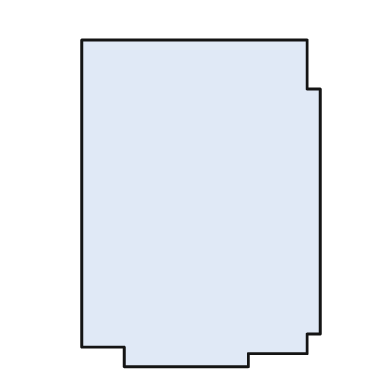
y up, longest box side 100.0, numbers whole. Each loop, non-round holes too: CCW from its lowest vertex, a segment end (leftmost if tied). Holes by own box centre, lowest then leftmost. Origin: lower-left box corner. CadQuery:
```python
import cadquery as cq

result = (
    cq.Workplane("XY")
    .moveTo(13.0, 0.0)
    .lineTo(51.0, 0.0)
    .lineTo(51.0, 4.0)
    .lineTo(69.0, 4.0)
    .lineTo(69.0, 10.0)
    .lineTo(73.0, 10.0)
    .lineTo(73.0, 85.0)
    .lineTo(69.0, 85.0)
    .lineTo(69.0, 100.0)
    .lineTo(0.0, 100.0)
    .lineTo(0.0, 6.0)
    .lineTo(13.0, 6.0)
    .close()
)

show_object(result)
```